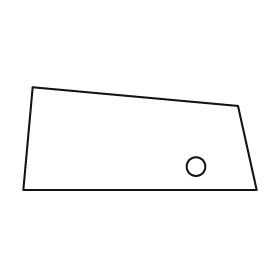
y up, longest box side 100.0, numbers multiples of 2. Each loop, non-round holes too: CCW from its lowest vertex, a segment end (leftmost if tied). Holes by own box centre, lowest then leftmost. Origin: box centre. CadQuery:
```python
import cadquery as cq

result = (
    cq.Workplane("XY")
    .moveTo(-50.0, -22.0)
    .lineTo(50.0, -22.0)
    .lineTo(42.0, 14.0)
    .lineTo(-46.0, 22.0)
    .close()
    .moveTo(24.0, -12.0)
    .circle(4.0)
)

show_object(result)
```